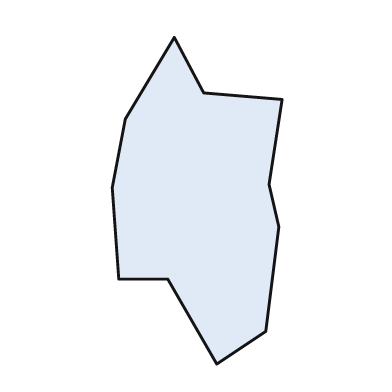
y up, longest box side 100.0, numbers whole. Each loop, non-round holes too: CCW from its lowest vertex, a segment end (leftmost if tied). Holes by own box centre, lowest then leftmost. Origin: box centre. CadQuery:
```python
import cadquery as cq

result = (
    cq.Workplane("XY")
    .moveTo(6.0, -50.0)
    .lineTo(21.0, -40.0)
    .lineTo(25.0, -8.0)
    .lineTo(22.0, 5.0)
    .lineTo(26.0, 31.0)
    .lineTo(2.0, 33.0)
    .lineTo(-7.0, 50.0)
    .lineTo(-22.0, 25.0)
    .lineTo(-26.0, 4.0)
    .lineTo(-24.0, -24.0)
    .lineTo(-9.0, -24.0)
    .close()
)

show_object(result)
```